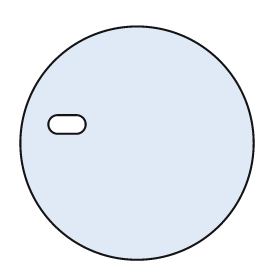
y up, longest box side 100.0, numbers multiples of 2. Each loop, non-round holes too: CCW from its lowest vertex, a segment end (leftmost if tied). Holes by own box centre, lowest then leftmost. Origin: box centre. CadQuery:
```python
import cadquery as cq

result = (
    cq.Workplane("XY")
    .moveTo(0.0, 0.0)
    .circle(50.0)
    .moveTo(-34.0, 4.0)
    .lineTo(-26.0, 4.0)
    .threePointArc((-22.0, 8.0), (-26.0, 12.0))
    .lineTo(-34.0, 12.0)
    .threePointArc((-38.0, 8.0), (-34.0, 4.0))
    .close()
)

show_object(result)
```